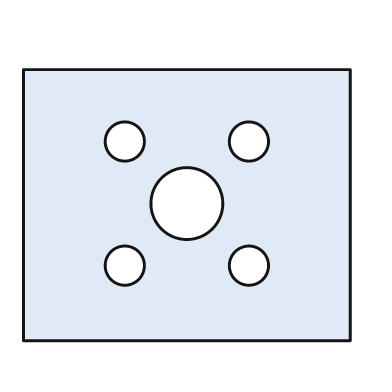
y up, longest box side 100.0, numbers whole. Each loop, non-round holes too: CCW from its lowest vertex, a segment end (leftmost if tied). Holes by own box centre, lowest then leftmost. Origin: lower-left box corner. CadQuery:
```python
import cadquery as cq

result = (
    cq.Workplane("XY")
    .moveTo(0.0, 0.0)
    .lineTo(100.0, 0.0)
    .lineTo(100.0, 83.0)
    .lineTo(0.0, 83.0)
    .close()
    .moveTo(31.0, 23.0)
    .circle(6.0)
    .moveTo(69.0, 23.0)
    .circle(6.0)
    .moveTo(50.0, 42.0)
    .circle(11.0)
    .moveTo(31.0, 61.0)
    .circle(6.0)
    .moveTo(69.0, 61.0)
    .circle(6.0)
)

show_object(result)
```